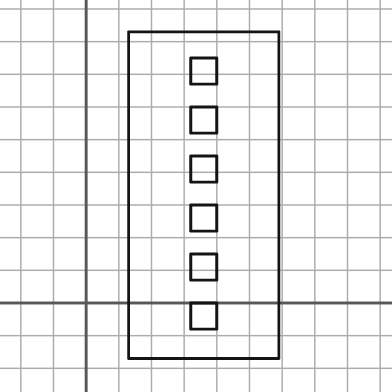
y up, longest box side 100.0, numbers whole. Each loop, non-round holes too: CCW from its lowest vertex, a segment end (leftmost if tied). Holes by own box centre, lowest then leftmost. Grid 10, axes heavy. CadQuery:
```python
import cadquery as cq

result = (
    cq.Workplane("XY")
    .moveTo(13.0, -17.0)
    .lineTo(59.0, -17.0)
    .lineTo(59.0, 83.0)
    .lineTo(13.0, 83.0)
    .close()
    .moveTo(32.0, -8.0)
    .lineTo(40.0, -8.0)
    .lineTo(40.0, 0.0)
    .lineTo(32.0, 0.0)
    .close()
    .moveTo(32.0, 7.0)
    .lineTo(40.0, 7.0)
    .lineTo(40.0, 15.0)
    .lineTo(32.0, 15.0)
    .close()
    .moveTo(32.0, 22.0)
    .lineTo(40.0, 22.0)
    .lineTo(40.0, 30.0)
    .lineTo(32.0, 30.0)
    .close()
    .moveTo(32.0, 37.0)
    .lineTo(40.0, 37.0)
    .lineTo(40.0, 45.0)
    .lineTo(32.0, 45.0)
    .close()
    .moveTo(32.0, 52.0)
    .lineTo(40.0, 52.0)
    .lineTo(40.0, 60.0)
    .lineTo(32.0, 60.0)
    .close()
    .moveTo(32.0, 67.0)
    .lineTo(40.0, 67.0)
    .lineTo(40.0, 75.0)
    .lineTo(32.0, 75.0)
    .close()
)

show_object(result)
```